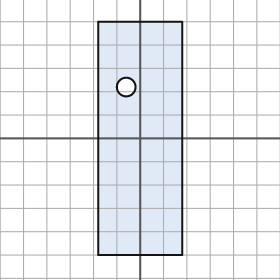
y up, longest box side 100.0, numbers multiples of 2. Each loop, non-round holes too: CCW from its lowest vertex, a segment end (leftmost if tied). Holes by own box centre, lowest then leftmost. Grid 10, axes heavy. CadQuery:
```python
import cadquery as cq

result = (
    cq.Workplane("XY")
    .moveTo(-18.0, -50.0)
    .lineTo(18.0, -50.0)
    .lineTo(18.0, 50.0)
    .lineTo(-18.0, 50.0)
    .close()
    .moveTo(-6.0, 22.0)
    .circle(4.0)
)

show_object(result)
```